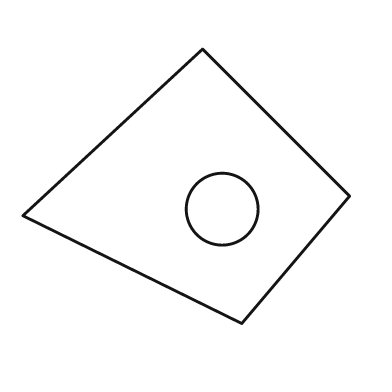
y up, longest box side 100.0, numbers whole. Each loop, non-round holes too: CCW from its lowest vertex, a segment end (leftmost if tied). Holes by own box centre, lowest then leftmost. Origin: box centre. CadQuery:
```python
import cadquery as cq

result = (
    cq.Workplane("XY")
    .moveTo(17.0, -42.0)
    .lineTo(50.0, -3.0)
    .lineTo(5.0, 42.0)
    .lineTo(-50.0, -9.0)
    .close()
    .moveTo(11.0, -7.0)
    .circle(11.0)
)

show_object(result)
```